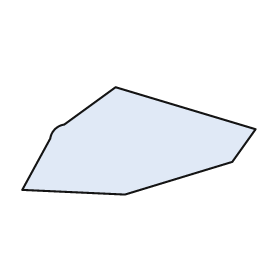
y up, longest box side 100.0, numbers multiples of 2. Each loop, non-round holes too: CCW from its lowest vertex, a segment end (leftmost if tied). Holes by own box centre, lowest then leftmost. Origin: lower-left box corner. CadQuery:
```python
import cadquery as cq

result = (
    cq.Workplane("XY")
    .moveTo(44.0, 0.0)
    .lineTo(90.0, 14.0)
    .lineTo(100.0, 28.0)
    .lineTo(40.0, 46.0)
    .lineTo(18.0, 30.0)
    .threePointArc((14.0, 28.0), (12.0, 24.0))
    .lineTo(0.0, 2.0)
    .close()
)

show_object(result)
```